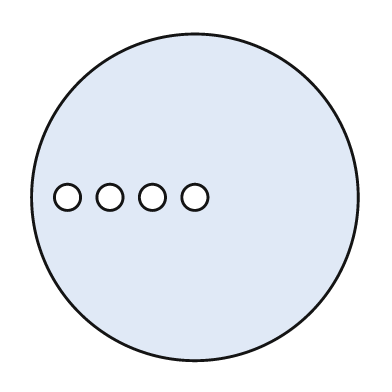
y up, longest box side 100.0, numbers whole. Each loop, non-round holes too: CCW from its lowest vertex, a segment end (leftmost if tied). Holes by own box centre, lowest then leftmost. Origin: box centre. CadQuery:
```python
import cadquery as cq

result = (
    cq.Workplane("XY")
    .moveTo(0.0, 0.0)
    .circle(50.0)
    .moveTo(-39.0, 0.0)
    .circle(4.0)
    .moveTo(-26.0, 0.0)
    .circle(4.0)
    .moveTo(-13.0, 0.0)
    .circle(4.0)
    .moveTo(0.0, 0.0)
    .circle(4.0)
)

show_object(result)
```